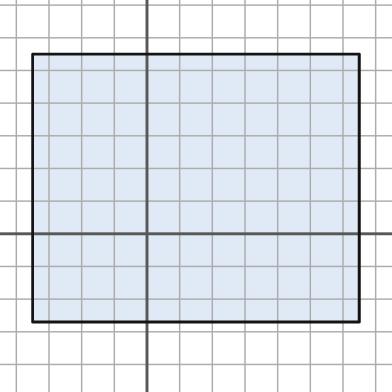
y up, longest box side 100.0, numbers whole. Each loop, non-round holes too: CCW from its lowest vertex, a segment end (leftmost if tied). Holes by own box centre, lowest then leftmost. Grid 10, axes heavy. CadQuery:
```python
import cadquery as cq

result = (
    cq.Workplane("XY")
    .moveTo(-35.0, -27.0)
    .lineTo(65.0, -27.0)
    .lineTo(65.0, 55.0)
    .lineTo(-35.0, 55.0)
    .close()
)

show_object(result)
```